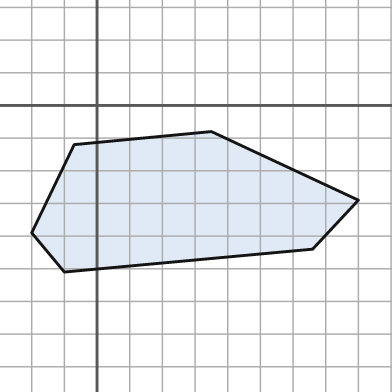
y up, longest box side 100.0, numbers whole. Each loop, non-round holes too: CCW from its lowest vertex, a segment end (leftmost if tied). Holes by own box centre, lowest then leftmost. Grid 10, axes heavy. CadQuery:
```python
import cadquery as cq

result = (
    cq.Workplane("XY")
    .moveTo(-10.0, -51.0)
    .lineTo(66.0, -44.0)
    .lineTo(80.0, -29.0)
    .lineTo(35.0, -8.0)
    .lineTo(-7.0, -12.0)
    .lineTo(-20.0, -39.0)
    .close()
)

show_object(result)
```